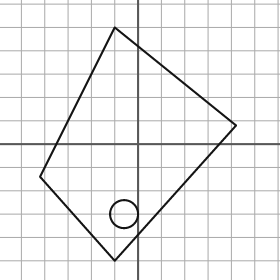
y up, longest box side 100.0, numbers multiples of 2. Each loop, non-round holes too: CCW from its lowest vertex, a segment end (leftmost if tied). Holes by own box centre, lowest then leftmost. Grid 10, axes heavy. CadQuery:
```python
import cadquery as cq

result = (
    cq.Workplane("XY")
    .moveTo(-10.0, -50.0)
    .lineTo(42.0, 8.0)
    .lineTo(-10.0, 50.0)
    .lineTo(-42.0, -14.0)
    .close()
    .moveTo(-6.0, -30.0)
    .circle(6.0)
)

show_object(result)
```